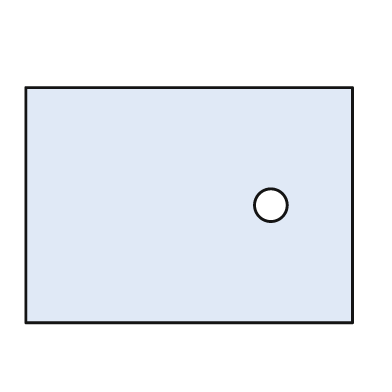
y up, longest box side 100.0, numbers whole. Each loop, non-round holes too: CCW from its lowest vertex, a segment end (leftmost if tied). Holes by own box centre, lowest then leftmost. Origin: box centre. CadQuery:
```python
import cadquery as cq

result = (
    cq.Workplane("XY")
    .moveTo(-50.0, -36.0)
    .lineTo(50.0, -36.0)
    .lineTo(50.0, 36.0)
    .lineTo(-50.0, 36.0)
    .close()
    .moveTo(25.0, 0.0)
    .circle(5.0)
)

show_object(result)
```